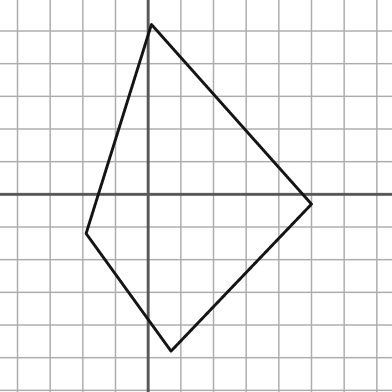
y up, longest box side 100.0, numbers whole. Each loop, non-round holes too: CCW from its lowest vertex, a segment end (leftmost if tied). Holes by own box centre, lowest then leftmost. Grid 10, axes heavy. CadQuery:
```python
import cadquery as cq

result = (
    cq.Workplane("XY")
    .moveTo(7.0, -48.0)
    .lineTo(50.0, -3.0)
    .lineTo(1.0, 52.0)
    .lineTo(-19.0, -12.0)
    .close()
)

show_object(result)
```